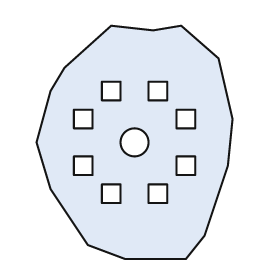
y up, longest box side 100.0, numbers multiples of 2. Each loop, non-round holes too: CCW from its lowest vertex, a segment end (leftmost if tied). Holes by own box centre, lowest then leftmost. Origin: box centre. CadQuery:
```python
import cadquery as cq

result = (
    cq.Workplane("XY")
    .moveTo(-4.0, -50.0)
    .lineTo(22.0, -50.0)
    .lineTo(30.0, -40.0)
    .lineTo(40.0, -10.0)
    .lineTo(42.0, 10.0)
    .lineTo(36.0, 36.0)
    .lineTo(20.0, 50.0)
    .lineTo(8.0, 48.0)
    .lineTo(-10.0, 50.0)
    .lineTo(-30.0, 32.0)
    .lineTo(-36.0, 22.0)
    .lineTo(-42.0, 0.0)
    .lineTo(-36.0, -20.0)
    .lineTo(-20.0, -44.0)
    .close()
    .moveTo(-14.0, -26.0)
    .lineTo(-6.0, -26.0)
    .lineTo(-6.0, -18.0)
    .lineTo(-14.0, -18.0)
    .close()
    .moveTo(6.0, -26.0)
    .lineTo(14.0, -26.0)
    .lineTo(14.0, -18.0)
    .lineTo(6.0, -18.0)
    .close()
    .moveTo(-26.0, -14.0)
    .lineTo(-18.0, -14.0)
    .lineTo(-18.0, -6.0)
    .lineTo(-26.0, -6.0)
    .close()
    .moveTo(18.0, -14.0)
    .lineTo(26.0, -14.0)
    .lineTo(26.0, -6.0)
    .lineTo(18.0, -6.0)
    .close()
    .moveTo(0.0, 0.0)
    .circle(6.0)
    .moveTo(-26.0, 6.0)
    .lineTo(-18.0, 6.0)
    .lineTo(-18.0, 14.0)
    .lineTo(-26.0, 14.0)
    .close()
    .moveTo(18.0, 6.0)
    .lineTo(26.0, 6.0)
    .lineTo(26.0, 14.0)
    .lineTo(18.0, 14.0)
    .close()
    .moveTo(-14.0, 18.0)
    .lineTo(-6.0, 18.0)
    .lineTo(-6.0, 26.0)
    .lineTo(-14.0, 26.0)
    .close()
    .moveTo(6.0, 18.0)
    .lineTo(14.0, 18.0)
    .lineTo(14.0, 26.0)
    .lineTo(6.0, 26.0)
    .close()
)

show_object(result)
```